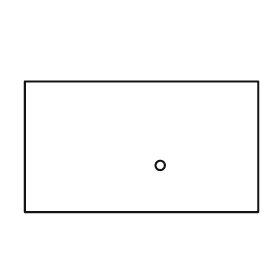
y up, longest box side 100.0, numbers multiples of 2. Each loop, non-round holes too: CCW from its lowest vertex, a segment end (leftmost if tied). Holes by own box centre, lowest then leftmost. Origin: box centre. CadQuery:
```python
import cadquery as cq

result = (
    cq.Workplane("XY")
    .moveTo(-50.0, -28.0)
    .lineTo(50.0, -28.0)
    .lineTo(50.0, 28.0)
    .lineTo(-50.0, 28.0)
    .close()
    .moveTo(8.0, -8.0)
    .circle(2.0)
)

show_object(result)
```